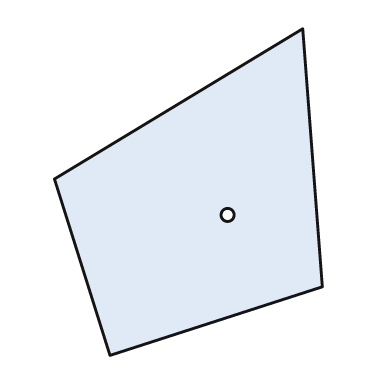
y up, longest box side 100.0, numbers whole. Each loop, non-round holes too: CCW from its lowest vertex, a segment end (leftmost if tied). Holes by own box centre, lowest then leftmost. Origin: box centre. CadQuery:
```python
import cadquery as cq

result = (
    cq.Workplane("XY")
    .moveTo(-24.0, -50.0)
    .lineTo(41.0, -29.0)
    .lineTo(35.0, 50.0)
    .lineTo(-41.0, 4.0)
    .close()
    .moveTo(12.0, -7.0)
    .circle(2.0)
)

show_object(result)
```